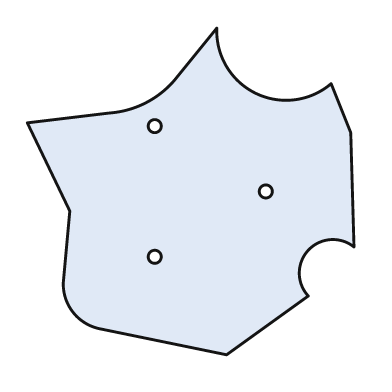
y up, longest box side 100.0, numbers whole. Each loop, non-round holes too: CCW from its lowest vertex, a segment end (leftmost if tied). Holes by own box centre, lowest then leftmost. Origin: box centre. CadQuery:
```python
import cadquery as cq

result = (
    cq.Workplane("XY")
    .moveTo(11.0, -50.0)
    .lineTo(36.0, -32.0)
    .threePointArc((36.0, -18.0), (50.0, -17.0))
    .lineTo(49.0, 18.0)
    .lineTo(43.0, 33.0)
    .threePointArc((20.0, 30.0), (8.0, 50.0))
    .lineTo(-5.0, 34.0)
    .threePointArc((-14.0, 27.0), (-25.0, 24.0))
    .lineTo(-50.0, 21.0)
    .lineTo(-37.0, -6.0)
    .lineTo(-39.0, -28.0)
    .threePointArc((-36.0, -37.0), (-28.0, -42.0))
    .close()
    .moveTo(-11.0, -20.0)
    .circle(2.0)
    .moveTo(23.0, 0.0)
    .circle(2.0)
    .moveTo(-11.0, 20.0)
    .circle(2.0)
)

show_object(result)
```